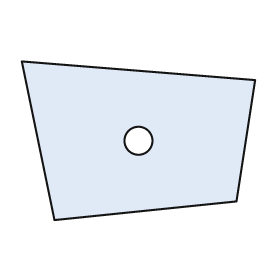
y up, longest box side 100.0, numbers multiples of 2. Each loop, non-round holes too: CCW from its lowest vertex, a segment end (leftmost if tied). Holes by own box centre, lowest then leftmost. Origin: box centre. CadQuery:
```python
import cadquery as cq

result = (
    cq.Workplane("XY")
    .moveTo(-36.0, -34.0)
    .lineTo(42.0, -26.0)
    .lineTo(50.0, 26.0)
    .lineTo(-50.0, 34.0)
    .close()
    .moveTo(0.0, 0.0)
    .circle(6.0)
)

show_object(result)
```